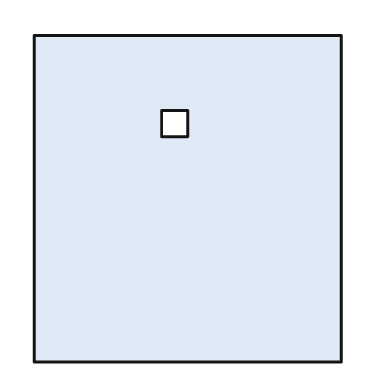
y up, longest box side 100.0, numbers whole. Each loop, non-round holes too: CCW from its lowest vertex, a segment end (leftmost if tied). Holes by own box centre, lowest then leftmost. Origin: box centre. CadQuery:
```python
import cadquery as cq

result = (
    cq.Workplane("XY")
    .moveTo(-47.0, -50.0)
    .lineTo(47.0, -50.0)
    .lineTo(47.0, 50.0)
    .lineTo(-47.0, 50.0)
    .close()
    .moveTo(-8.0, 19.0)
    .lineTo(0.0, 19.0)
    .lineTo(0.0, 27.0)
    .lineTo(-8.0, 27.0)
    .close()
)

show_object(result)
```